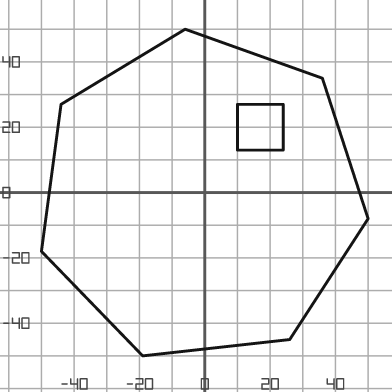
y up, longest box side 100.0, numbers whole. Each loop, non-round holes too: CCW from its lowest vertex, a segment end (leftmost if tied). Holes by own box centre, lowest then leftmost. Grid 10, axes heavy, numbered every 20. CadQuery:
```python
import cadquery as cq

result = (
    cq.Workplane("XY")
    .moveTo(-19.0, -50.0)
    .lineTo(26.0, -45.0)
    .lineTo(50.0, -8.0)
    .lineTo(36.0, 35.0)
    .lineTo(-6.0, 50.0)
    .lineTo(-44.0, 27.0)
    .lineTo(-50.0, -18.0)
    .close()
    .moveTo(10.0, 13.0)
    .lineTo(24.0, 13.0)
    .lineTo(24.0, 27.0)
    .lineTo(10.0, 27.0)
    .close()
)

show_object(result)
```